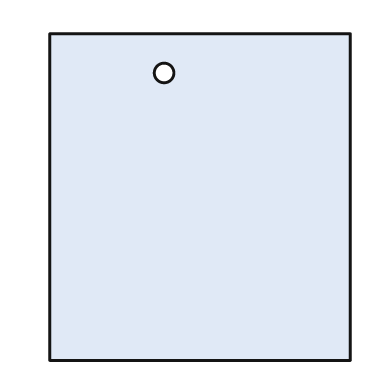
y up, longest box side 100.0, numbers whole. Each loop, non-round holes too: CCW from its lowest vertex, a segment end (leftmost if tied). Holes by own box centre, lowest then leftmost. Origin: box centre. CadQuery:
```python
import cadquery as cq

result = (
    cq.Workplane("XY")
    .moveTo(-46.0, -50.0)
    .lineTo(46.0, -50.0)
    .lineTo(46.0, 50.0)
    .lineTo(-46.0, 50.0)
    .close()
    .moveTo(-11.0, 38.0)
    .circle(3.0)
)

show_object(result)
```